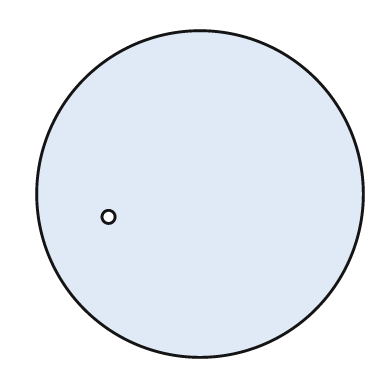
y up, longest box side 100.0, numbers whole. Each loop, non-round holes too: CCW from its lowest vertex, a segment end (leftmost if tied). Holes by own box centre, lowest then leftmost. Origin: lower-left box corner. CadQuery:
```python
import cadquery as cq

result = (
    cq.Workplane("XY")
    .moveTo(50.0, 50.0)
    .circle(50.0)
    .moveTo(22.0, 43.0)
    .circle(2.0)
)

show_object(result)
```